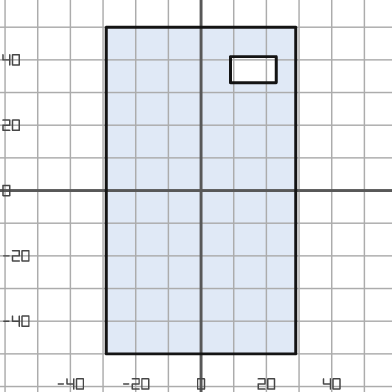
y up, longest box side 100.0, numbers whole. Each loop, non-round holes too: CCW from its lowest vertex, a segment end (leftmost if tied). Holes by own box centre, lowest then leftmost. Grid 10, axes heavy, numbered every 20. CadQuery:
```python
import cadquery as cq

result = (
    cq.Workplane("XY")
    .moveTo(-29.0, -50.0)
    .lineTo(29.0, -50.0)
    .lineTo(29.0, 50.0)
    .lineTo(-29.0, 50.0)
    .close()
    .moveTo(9.0, 33.0)
    .lineTo(23.0, 33.0)
    .lineTo(23.0, 41.0)
    .lineTo(9.0, 41.0)
    .close()
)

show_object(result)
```